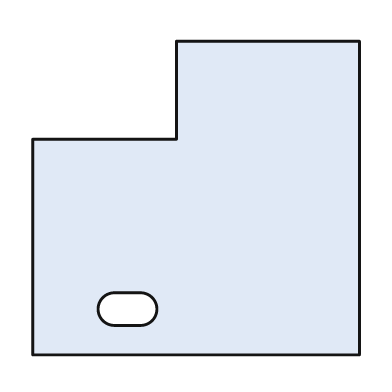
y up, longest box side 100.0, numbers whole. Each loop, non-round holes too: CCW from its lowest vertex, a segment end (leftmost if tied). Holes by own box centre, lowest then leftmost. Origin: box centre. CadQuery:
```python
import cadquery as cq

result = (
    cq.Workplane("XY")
    .moveTo(-50.0, -48.0)
    .lineTo(50.0, -48.0)
    .lineTo(50.0, 48.0)
    .lineTo(-6.0, 48.0)
    .lineTo(-6.0, 18.0)
    .lineTo(-50.0, 18.0)
    .close()
    .moveTo(-25.0, -39.0)
    .lineTo(-17.0, -39.0)
    .threePointArc((-12.0, -34.0), (-17.0, -29.0))
    .lineTo(-25.0, -29.0)
    .threePointArc((-30.0, -34.0), (-25.0, -39.0))
    .close()
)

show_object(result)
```